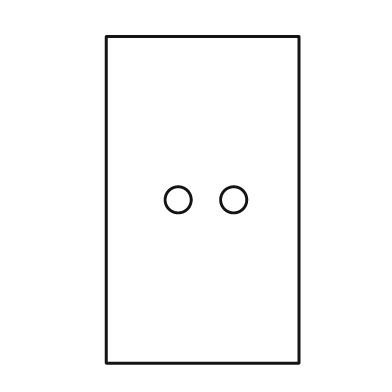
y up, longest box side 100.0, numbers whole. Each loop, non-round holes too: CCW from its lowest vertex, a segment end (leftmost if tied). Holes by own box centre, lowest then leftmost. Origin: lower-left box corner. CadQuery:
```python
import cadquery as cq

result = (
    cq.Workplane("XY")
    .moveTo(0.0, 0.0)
    .lineTo(59.0, 0.0)
    .lineTo(59.0, 100.0)
    .lineTo(0.0, 100.0)
    .close()
    .moveTo(22.0, 50.0)
    .circle(4.0)
    .moveTo(39.0, 50.0)
    .circle(4.0)
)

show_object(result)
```